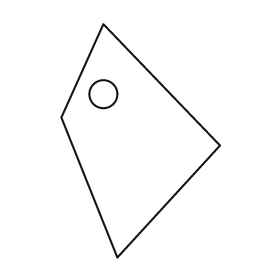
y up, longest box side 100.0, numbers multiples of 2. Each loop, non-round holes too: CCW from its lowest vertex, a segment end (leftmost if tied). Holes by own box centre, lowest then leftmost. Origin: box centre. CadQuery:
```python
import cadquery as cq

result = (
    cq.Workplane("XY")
    .moveTo(-10.0, -50.0)
    .lineTo(34.0, -2.0)
    .lineTo(-16.0, 50.0)
    .lineTo(-34.0, 10.0)
    .close()
    .moveTo(-16.0, 20.0)
    .circle(6.0)
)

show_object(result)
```